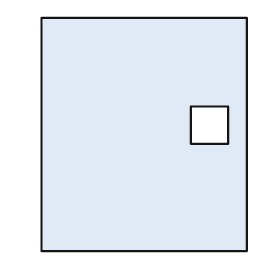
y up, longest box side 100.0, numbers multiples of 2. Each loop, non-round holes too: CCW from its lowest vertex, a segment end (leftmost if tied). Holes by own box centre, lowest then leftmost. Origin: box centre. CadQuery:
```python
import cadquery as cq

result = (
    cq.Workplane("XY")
    .moveTo(-44.0, -50.0)
    .lineTo(44.0, -50.0)
    .lineTo(44.0, 50.0)
    .lineTo(-44.0, 50.0)
    .close()
    .moveTo(20.0, -4.0)
    .lineTo(36.0, -4.0)
    .lineTo(36.0, 12.0)
    .lineTo(20.0, 12.0)
    .close()
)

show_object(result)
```